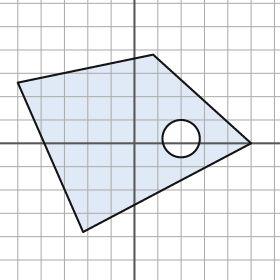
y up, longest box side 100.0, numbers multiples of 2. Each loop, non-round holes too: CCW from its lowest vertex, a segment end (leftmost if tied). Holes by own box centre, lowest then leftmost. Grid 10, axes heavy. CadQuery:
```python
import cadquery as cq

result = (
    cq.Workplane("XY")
    .moveTo(-22.0, -38.0)
    .lineTo(50.0, 0.0)
    .lineTo(8.0, 38.0)
    .lineTo(-50.0, 26.0)
    .close()
    .moveTo(20.0, 2.0)
    .circle(8.0)
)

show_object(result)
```